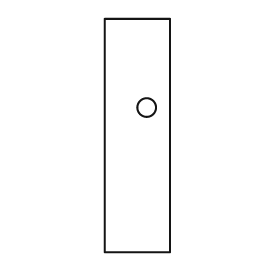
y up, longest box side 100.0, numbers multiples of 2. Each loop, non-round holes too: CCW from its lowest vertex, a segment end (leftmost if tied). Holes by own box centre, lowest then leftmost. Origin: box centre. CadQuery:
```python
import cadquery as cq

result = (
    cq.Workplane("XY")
    .moveTo(-14.0, -50.0)
    .lineTo(14.0, -50.0)
    .lineTo(14.0, 50.0)
    .lineTo(-14.0, 50.0)
    .close()
    .moveTo(4.0, 12.0)
    .circle(4.0)
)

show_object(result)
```